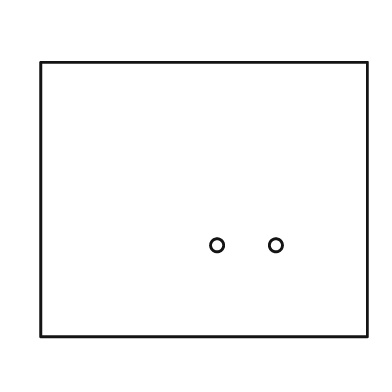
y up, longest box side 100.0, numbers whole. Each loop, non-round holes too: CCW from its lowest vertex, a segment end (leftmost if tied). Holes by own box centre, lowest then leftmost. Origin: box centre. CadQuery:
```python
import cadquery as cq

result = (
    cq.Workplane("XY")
    .moveTo(-50.0, -42.0)
    .lineTo(50.0, -42.0)
    .lineTo(50.0, 42.0)
    .lineTo(-50.0, 42.0)
    .close()
    .moveTo(4.0, -14.0)
    .circle(2.0)
    .moveTo(22.0, -14.0)
    .circle(2.0)
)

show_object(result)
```